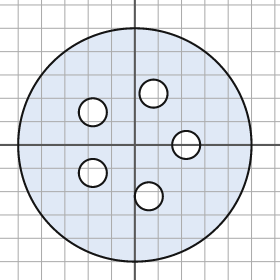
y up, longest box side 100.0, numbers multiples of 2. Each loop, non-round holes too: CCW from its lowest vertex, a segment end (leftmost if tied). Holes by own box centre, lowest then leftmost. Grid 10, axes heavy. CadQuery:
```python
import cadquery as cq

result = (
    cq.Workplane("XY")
    .moveTo(0.0, 0.0)
    .circle(50.0)
    .moveTo(6.0, -22.0)
    .circle(6.0)
    .moveTo(-18.0, -12.0)
    .circle(6.0)
    .moveTo(22.0, 0.0)
    .circle(6.0)
    .moveTo(-18.0, 14.0)
    .circle(6.0)
    .moveTo(8.0, 22.0)
    .circle(6.0)
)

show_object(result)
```